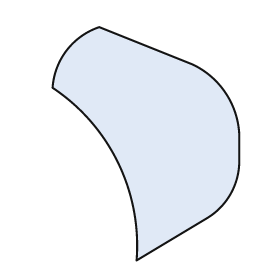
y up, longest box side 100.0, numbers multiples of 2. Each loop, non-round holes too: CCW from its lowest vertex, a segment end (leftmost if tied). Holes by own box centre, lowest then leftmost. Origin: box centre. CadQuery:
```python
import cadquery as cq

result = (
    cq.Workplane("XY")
    .moveTo(-4.0, -50.0)
    .lineTo(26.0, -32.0)
    .threePointArc((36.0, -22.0), (40.0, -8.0))
    .lineTo(40.0, 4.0)
    .threePointArc((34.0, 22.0), (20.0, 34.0))
    .lineTo(-20.0, 50.0)
    .threePointArc((-34.0, 40.0), (-40.0, 24.0))
    .threePointArc((-12.0, -8.0), (-4.0, -50.0))
    .close()
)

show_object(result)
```